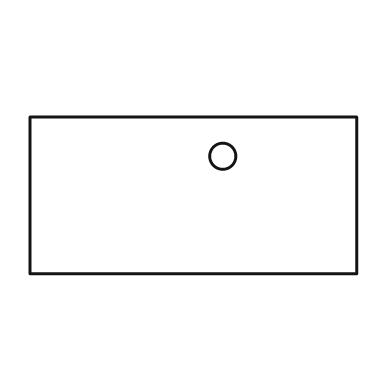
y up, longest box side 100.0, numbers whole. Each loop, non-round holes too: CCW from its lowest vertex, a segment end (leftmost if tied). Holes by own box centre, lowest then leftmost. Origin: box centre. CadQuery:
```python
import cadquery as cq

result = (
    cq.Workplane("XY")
    .moveTo(-50.0, -24.0)
    .lineTo(50.0, -24.0)
    .lineTo(50.0, 24.0)
    .lineTo(-50.0, 24.0)
    .close()
    .moveTo(9.0, 12.0)
    .circle(4.0)
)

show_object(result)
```